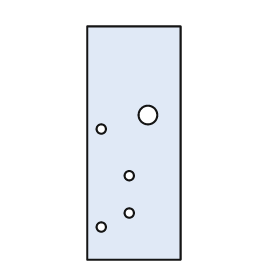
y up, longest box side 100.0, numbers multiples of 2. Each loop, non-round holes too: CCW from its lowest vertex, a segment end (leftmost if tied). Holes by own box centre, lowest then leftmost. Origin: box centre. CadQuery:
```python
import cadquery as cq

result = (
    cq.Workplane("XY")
    .moveTo(-20.0, -50.0)
    .lineTo(20.0, -50.0)
    .lineTo(20.0, 50.0)
    .lineTo(-20.0, 50.0)
    .close()
    .moveTo(-14.0, -36.0)
    .circle(2.0)
    .moveTo(-2.0, -30.0)
    .circle(2.0)
    .moveTo(-2.0, -14.0)
    .circle(2.0)
    .moveTo(-14.0, 6.0)
    .circle(2.0)
    .moveTo(6.0, 12.0)
    .circle(4.0)
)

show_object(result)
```